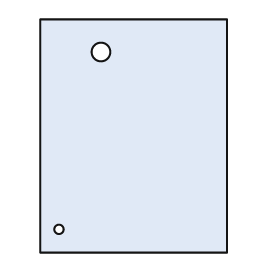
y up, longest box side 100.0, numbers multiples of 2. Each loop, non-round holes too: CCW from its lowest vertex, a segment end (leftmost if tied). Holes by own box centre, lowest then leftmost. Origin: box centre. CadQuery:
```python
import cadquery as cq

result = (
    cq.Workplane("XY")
    .moveTo(-40.0, -50.0)
    .lineTo(40.0, -50.0)
    .lineTo(40.0, 50.0)
    .lineTo(-40.0, 50.0)
    .close()
    .moveTo(-32.0, -40.0)
    .circle(2.0)
    .moveTo(-14.0, 36.0)
    .circle(4.0)
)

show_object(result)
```